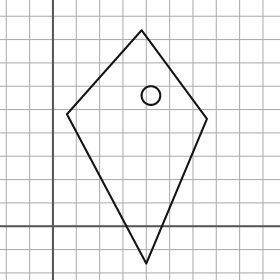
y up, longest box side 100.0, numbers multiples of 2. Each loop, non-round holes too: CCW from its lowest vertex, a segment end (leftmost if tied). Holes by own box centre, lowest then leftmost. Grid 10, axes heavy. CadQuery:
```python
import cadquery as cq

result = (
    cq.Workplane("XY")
    .moveTo(40.0, -16.0)
    .lineTo(66.0, 46.0)
    .lineTo(38.0, 84.0)
    .lineTo(6.0, 48.0)
    .close()
    .moveTo(42.0, 56.0)
    .circle(4.0)
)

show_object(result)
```